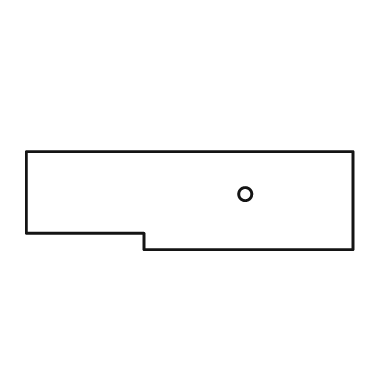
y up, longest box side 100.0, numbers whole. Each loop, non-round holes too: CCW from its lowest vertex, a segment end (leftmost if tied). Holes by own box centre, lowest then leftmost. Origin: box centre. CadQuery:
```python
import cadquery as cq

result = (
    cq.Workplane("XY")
    .moveTo(-14.0, -15.0)
    .lineTo(50.0, -15.0)
    .lineTo(50.0, 15.0)
    .lineTo(-50.0, 15.0)
    .lineTo(-50.0, -10.0)
    .lineTo(-14.0, -10.0)
    .close()
    .moveTo(17.0, 2.0)
    .circle(2.0)
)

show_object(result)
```